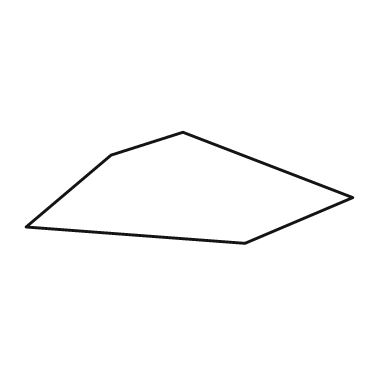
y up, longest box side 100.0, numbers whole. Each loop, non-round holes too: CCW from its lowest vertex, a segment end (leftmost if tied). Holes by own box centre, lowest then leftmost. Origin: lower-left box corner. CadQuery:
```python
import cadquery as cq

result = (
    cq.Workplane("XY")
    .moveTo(67.0, 0.0)
    .lineTo(100.0, 14.0)
    .lineTo(48.0, 34.0)
    .lineTo(26.0, 27.0)
    .lineTo(0.0, 5.0)
    .close()
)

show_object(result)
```